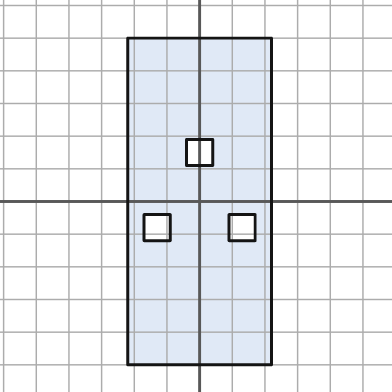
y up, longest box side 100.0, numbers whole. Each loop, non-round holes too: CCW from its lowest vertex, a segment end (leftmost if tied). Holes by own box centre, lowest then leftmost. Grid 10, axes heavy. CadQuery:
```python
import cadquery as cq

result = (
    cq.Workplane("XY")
    .moveTo(-22.0, -50.0)
    .lineTo(22.0, -50.0)
    .lineTo(22.0, 50.0)
    .lineTo(-22.0, 50.0)
    .close()
    .moveTo(-17.0, -12.0)
    .lineTo(-9.0, -12.0)
    .lineTo(-9.0, -4.0)
    .lineTo(-17.0, -4.0)
    .close()
    .moveTo(9.0, -12.0)
    .lineTo(17.0, -12.0)
    .lineTo(17.0, -4.0)
    .lineTo(9.0, -4.0)
    .close()
    .moveTo(-4.0, 11.0)
    .lineTo(4.0, 11.0)
    .lineTo(4.0, 19.0)
    .lineTo(-4.0, 19.0)
    .close()
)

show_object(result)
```